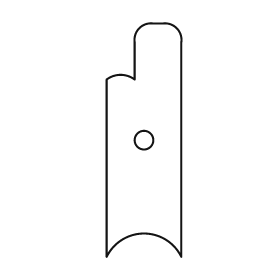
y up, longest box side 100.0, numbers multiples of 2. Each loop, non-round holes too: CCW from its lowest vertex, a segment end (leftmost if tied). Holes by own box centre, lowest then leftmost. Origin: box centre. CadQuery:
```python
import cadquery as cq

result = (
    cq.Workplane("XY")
    .moveTo(-16.0, -50.0)
    .threePointArc((0.0, -40.0), (16.0, -50.0))
    .lineTo(16.0, 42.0)
    .threePointArc((14.0, 48.0), (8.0, 50.0))
    .lineTo(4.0, 50.0)
    .threePointArc((-2.0, 48.0), (-4.0, 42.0))
    .lineTo(-4.0, 26.0)
    .threePointArc((-10.0, 28.0), (-16.0, 26.0))
    .close()
    .moveTo(0.0, 0.0)
    .circle(4.0)
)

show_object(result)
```